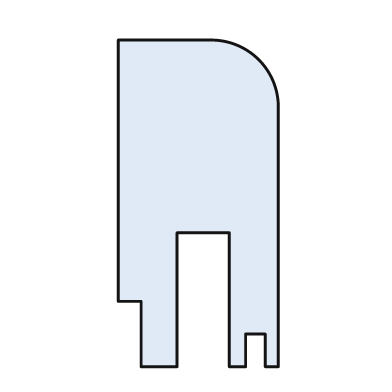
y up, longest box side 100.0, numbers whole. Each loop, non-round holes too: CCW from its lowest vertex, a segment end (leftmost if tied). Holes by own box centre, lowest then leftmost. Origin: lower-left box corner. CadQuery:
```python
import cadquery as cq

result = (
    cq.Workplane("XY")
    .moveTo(7.0, 0.0)
    .lineTo(18.0, 0.0)
    .lineTo(18.0, 41.0)
    .lineTo(34.0, 41.0)
    .lineTo(34.0, 0.0)
    .lineTo(39.0, 0.0)
    .lineTo(39.0, 10.0)
    .lineTo(45.0, 10.0)
    .lineTo(45.0, 0.0)
    .lineTo(49.0, 0.0)
    .lineTo(49.0, 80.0)
    .threePointArc((43.0, 94.0), (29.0, 100.0))
    .lineTo(0.0, 100.0)
    .lineTo(0.0, 20.0)
    .lineTo(7.0, 20.0)
    .close()
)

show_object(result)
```